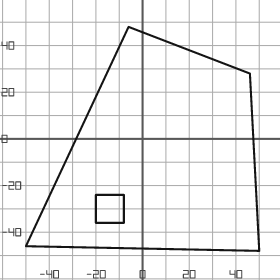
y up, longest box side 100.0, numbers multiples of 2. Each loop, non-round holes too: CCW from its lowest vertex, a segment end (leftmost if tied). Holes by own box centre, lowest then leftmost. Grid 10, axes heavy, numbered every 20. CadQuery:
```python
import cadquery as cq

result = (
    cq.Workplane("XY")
    .moveTo(50.0, -48.0)
    .lineTo(46.0, 28.0)
    .lineTo(-6.0, 48.0)
    .lineTo(-50.0, -46.0)
    .close()
    .moveTo(-20.0, -36.0)
    .lineTo(-8.0, -36.0)
    .lineTo(-8.0, -24.0)
    .lineTo(-20.0, -24.0)
    .close()
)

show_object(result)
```